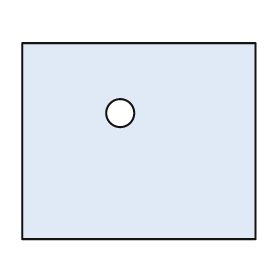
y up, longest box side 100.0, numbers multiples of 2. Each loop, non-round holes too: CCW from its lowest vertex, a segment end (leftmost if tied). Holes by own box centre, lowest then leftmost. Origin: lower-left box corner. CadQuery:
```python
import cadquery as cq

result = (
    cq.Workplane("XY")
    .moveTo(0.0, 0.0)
    .lineTo(100.0, 0.0)
    .lineTo(100.0, 84.0)
    .lineTo(0.0, 84.0)
    .close()
    .moveTo(42.0, 54.0)
    .circle(6.0)
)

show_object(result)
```